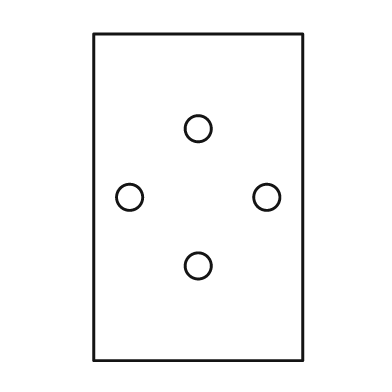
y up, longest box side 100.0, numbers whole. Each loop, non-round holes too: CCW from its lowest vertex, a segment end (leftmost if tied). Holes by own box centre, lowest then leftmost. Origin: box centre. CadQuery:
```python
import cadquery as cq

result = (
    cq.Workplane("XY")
    .moveTo(-32.0, -50.0)
    .lineTo(32.0, -50.0)
    .lineTo(32.0, 50.0)
    .lineTo(-32.0, 50.0)
    .close()
    .moveTo(0.0, -21.0)
    .circle(4.0)
    .moveTo(-21.0, 0.0)
    .circle(4.0)
    .moveTo(21.0, 0.0)
    .circle(4.0)
    .moveTo(0.0, 21.0)
    .circle(4.0)
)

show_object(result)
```